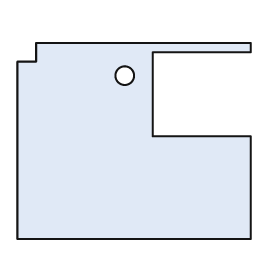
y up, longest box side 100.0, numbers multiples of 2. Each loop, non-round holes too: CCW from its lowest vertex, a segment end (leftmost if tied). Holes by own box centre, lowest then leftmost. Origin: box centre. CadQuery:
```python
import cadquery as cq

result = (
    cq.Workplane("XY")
    .moveTo(-50.0, -42.0)
    .lineTo(50.0, -42.0)
    .lineTo(50.0, 2.0)
    .lineTo(8.0, 2.0)
    .lineTo(8.0, 38.0)
    .lineTo(50.0, 38.0)
    .lineTo(50.0, 42.0)
    .lineTo(-42.0, 42.0)
    .lineTo(-42.0, 34.0)
    .lineTo(-50.0, 34.0)
    .close()
    .moveTo(-4.0, 28.0)
    .circle(4.0)
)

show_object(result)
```